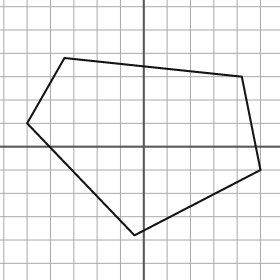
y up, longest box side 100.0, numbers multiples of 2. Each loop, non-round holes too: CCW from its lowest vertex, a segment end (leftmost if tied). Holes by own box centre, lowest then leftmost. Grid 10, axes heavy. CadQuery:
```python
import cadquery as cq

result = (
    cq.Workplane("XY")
    .moveTo(-4.0, -38.0)
    .lineTo(50.0, -10.0)
    .lineTo(42.0, 30.0)
    .lineTo(-34.0, 38.0)
    .lineTo(-50.0, 10.0)
    .close()
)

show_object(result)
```